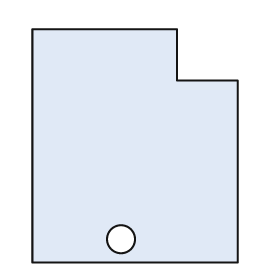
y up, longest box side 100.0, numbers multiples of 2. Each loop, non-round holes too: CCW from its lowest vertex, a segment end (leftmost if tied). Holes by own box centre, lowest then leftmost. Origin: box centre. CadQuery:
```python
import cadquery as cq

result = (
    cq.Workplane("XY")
    .moveTo(-44.0, -50.0)
    .lineTo(44.0, -50.0)
    .lineTo(44.0, 28.0)
    .lineTo(18.0, 28.0)
    .lineTo(18.0, 50.0)
    .lineTo(-44.0, 50.0)
    .close()
    .moveTo(-6.0, -40.0)
    .circle(6.0)
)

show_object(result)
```